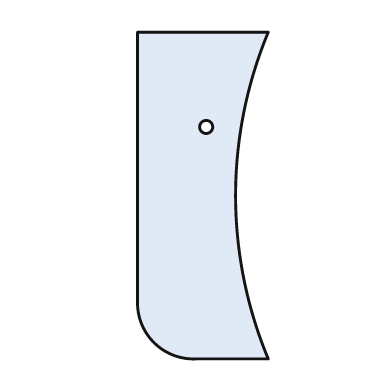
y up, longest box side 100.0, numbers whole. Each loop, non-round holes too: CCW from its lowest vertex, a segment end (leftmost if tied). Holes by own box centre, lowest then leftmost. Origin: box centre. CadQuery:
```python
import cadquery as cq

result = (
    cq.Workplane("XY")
    .moveTo(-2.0, -50.0)
    .lineTo(20.0, -50.0)
    .threePointArc((10.0, 0.0), (20.0, 50.0))
    .lineTo(-20.0, 50.0)
    .lineTo(-20.0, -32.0)
    .threePointArc((-15.0, -45.0), (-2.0, -50.0))
    .close()
    .moveTo(1.0, 21.0)
    .circle(2.0)
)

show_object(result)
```